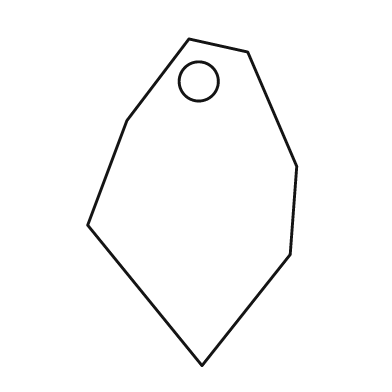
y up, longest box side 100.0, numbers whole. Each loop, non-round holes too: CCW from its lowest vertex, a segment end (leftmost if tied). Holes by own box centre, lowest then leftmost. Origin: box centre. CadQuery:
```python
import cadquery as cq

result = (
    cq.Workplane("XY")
    .moveTo(3.0, -50.0)
    .lineTo(30.0, -16.0)
    .lineTo(32.0, 11.0)
    .lineTo(17.0, 46.0)
    .lineTo(-1.0, 50.0)
    .lineTo(-20.0, 25.0)
    .lineTo(-32.0, -7.0)
    .close()
    .moveTo(2.0, 37.0)
    .circle(6.0)
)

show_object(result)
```